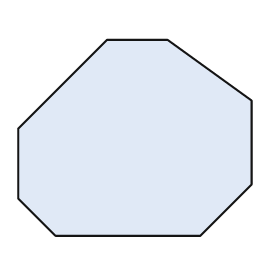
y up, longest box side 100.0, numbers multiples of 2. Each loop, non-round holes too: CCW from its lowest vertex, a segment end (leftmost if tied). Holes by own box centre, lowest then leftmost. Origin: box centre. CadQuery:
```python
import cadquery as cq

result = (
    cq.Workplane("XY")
    .moveTo(-34.0, -42.0)
    .lineTo(28.0, -42.0)
    .lineTo(50.0, -20.0)
    .lineTo(50.0, 16.0)
    .lineTo(14.0, 42.0)
    .lineTo(-12.0, 42.0)
    .lineTo(-50.0, 4.0)
    .lineTo(-50.0, -26.0)
    .close()
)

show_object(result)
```